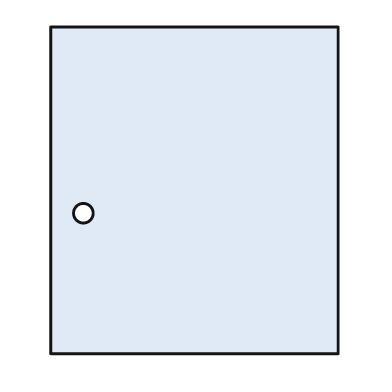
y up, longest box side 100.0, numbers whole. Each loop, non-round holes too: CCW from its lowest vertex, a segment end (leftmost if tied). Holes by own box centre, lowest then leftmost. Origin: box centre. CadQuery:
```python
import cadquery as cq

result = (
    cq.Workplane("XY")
    .moveTo(-44.0, -50.0)
    .lineTo(44.0, -50.0)
    .lineTo(44.0, 50.0)
    .lineTo(-44.0, 50.0)
    .close()
    .moveTo(-34.0, -7.0)
    .circle(3.0)
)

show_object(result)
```